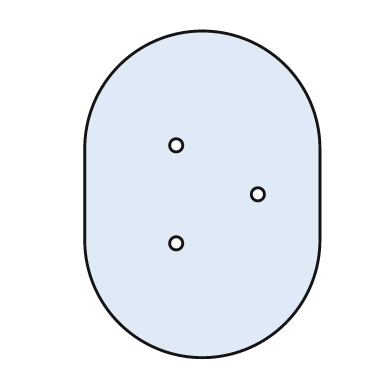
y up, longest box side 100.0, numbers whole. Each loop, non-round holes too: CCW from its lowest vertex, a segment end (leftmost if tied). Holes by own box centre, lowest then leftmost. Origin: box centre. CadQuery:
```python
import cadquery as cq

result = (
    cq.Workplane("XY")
    .moveTo(-36.0, -14.0)
    .threePointArc((0.0, -50.0), (36.0, -14.0))
    .lineTo(36.0, 14.0)
    .threePointArc((0.0, 50.0), (-36.0, 14.0))
    .close()
    .moveTo(-8.0, -15.0)
    .circle(2.0)
    .moveTo(17.0, 0.0)
    .circle(2.0)
    .moveTo(-8.0, 15.0)
    .circle(2.0)
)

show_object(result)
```